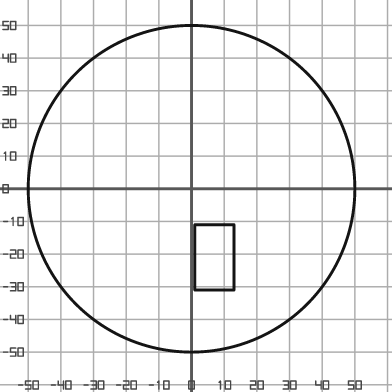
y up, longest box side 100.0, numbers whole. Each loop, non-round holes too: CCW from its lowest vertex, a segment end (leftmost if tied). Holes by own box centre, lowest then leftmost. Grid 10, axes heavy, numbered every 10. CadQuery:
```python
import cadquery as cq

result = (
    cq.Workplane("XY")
    .moveTo(0.0, 0.0)
    .circle(50.0)
    .moveTo(1.0, -31.0)
    .lineTo(13.0, -31.0)
    .lineTo(13.0, -11.0)
    .lineTo(1.0, -11.0)
    .close()
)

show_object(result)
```